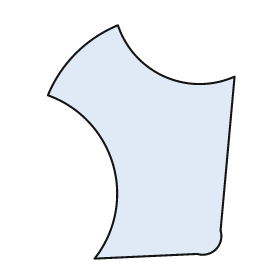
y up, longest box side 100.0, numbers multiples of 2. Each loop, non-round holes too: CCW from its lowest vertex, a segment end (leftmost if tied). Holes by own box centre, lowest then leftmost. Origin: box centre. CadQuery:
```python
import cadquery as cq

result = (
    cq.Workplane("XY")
    .moveTo(-20.0, -50.0)
    .lineTo(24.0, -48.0)
    .threePointArc((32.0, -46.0), (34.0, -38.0))
    .lineTo(40.0, 28.0)
    .threePointArc((10.0, 28.0), (-10.0, 50.0))
    .threePointArc((-28.0, 38.0), (-40.0, 20.0))
    .threePointArc((-12.0, -10.0), (-20.0, -50.0))
    .close()
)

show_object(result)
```